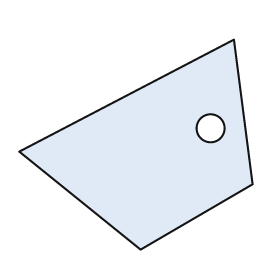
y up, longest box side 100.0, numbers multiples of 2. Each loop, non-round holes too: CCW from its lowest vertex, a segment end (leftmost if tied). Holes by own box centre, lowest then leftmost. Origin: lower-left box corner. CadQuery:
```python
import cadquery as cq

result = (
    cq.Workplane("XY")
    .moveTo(52.0, 0.0)
    .lineTo(100.0, 28.0)
    .lineTo(92.0, 90.0)
    .lineTo(0.0, 42.0)
    .close()
    .moveTo(82.0, 52.0)
    .circle(6.0)
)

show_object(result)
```